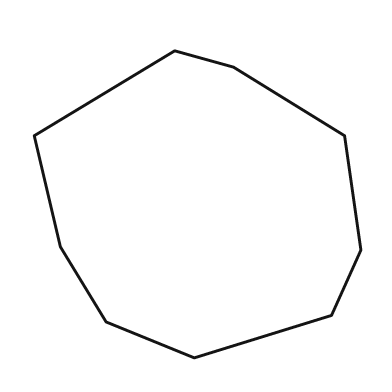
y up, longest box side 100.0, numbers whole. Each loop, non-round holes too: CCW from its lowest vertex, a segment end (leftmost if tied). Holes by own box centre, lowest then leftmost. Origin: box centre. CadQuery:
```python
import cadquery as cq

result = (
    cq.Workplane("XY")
    .moveTo(-1.0, -47.0)
    .lineTo(41.0, -34.0)
    .lineTo(50.0, -14.0)
    .lineTo(45.0, 21.0)
    .lineTo(11.0, 42.0)
    .lineTo(-7.0, 47.0)
    .lineTo(-50.0, 21.0)
    .lineTo(-42.0, -13.0)
    .lineTo(-28.0, -36.0)
    .close()
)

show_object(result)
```